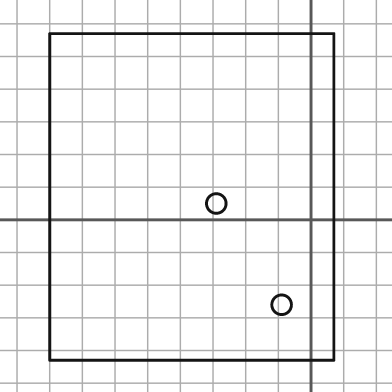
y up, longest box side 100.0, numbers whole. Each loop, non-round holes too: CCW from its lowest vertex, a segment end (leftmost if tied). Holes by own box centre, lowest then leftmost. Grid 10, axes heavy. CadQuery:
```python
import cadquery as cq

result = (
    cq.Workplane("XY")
    .moveTo(-80.0, -43.0)
    .lineTo(7.0, -43.0)
    .lineTo(7.0, 57.0)
    .lineTo(-80.0, 57.0)
    .close()
    .moveTo(-9.0, -26.0)
    .circle(3.0)
    .moveTo(-29.0, 5.0)
    .circle(3.0)
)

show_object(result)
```